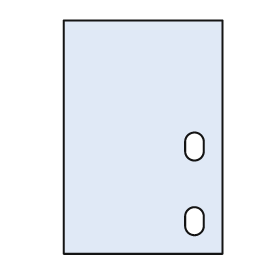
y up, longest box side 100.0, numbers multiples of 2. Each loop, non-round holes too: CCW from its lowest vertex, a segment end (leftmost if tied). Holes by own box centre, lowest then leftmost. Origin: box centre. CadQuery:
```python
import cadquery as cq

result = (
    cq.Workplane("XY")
    .moveTo(-34.0, -50.0)
    .lineTo(34.0, -50.0)
    .lineTo(34.0, 50.0)
    .lineTo(-34.0, 50.0)
    .close()
    .moveTo(18.0, -38.0)
    .threePointArc((22.0, -42.0), (26.0, -38.0))
    .lineTo(26.0, -34.0)
    .threePointArc((22.0, -30.0), (18.0, -34.0))
    .close()
    .moveTo(18.0, -6.0)
    .threePointArc((22.0, -10.0), (26.0, -6.0))
    .lineTo(26.0, -2.0)
    .threePointArc((22.0, 2.0), (18.0, -2.0))
    .close()
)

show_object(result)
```